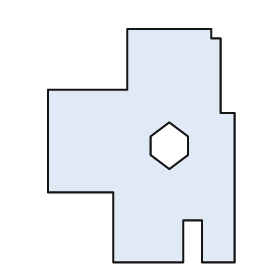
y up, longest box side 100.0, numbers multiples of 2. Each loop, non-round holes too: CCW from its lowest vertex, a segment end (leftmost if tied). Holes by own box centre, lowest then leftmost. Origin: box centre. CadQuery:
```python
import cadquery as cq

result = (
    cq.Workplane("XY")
    .moveTo(-12.0, -50.0)
    .lineTo(18.0, -50.0)
    .lineTo(18.0, -32.0)
    .lineTo(26.0, -32.0)
    .lineTo(26.0, -50.0)
    .lineTo(40.0, -50.0)
    .lineTo(40.0, 14.0)
    .lineTo(34.0, 14.0)
    .lineTo(34.0, 46.0)
    .lineTo(30.0, 46.0)
    .lineTo(30.0, 50.0)
    .lineTo(-6.0, 50.0)
    .lineTo(-6.0, 24.0)
    .lineTo(-40.0, 24.0)
    .lineTo(-40.0, -20.0)
    .lineTo(-12.0, -20.0)
    .close()
    .moveTo(12.0, -10.0)
    .lineTo(20.0, -4.0)
    .lineTo(20.0, 4.0)
    .lineTo(12.0, 10.0)
    .lineTo(4.0, 4.0)
    .lineTo(4.0, -4.0)
    .close()
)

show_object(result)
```